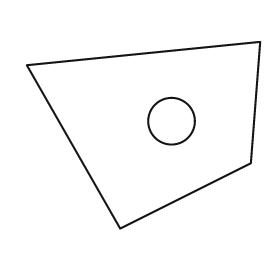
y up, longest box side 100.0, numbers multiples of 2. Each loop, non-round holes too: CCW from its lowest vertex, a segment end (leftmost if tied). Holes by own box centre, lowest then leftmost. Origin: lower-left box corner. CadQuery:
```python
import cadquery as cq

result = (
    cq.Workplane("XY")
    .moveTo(40.0, 0.0)
    .lineTo(96.0, 28.0)
    .lineTo(100.0, 80.0)
    .lineTo(0.0, 70.0)
    .close()
    .moveTo(62.0, 46.0)
    .circle(10.0)
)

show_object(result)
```